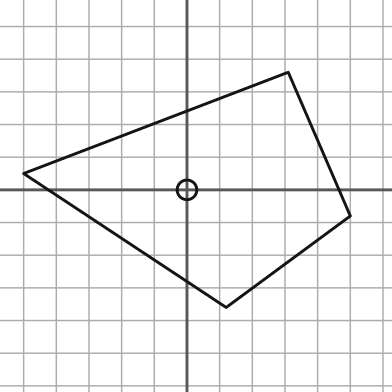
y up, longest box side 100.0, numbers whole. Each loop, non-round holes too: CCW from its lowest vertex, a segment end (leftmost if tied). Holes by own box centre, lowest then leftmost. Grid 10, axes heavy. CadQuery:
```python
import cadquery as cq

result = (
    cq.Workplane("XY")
    .moveTo(12.0, -36.0)
    .lineTo(50.0, -8.0)
    .lineTo(31.0, 36.0)
    .lineTo(-50.0, 5.0)
    .close()
    .moveTo(0.0, 0.0)
    .circle(3.0)
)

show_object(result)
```